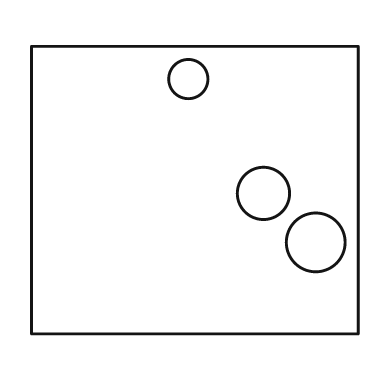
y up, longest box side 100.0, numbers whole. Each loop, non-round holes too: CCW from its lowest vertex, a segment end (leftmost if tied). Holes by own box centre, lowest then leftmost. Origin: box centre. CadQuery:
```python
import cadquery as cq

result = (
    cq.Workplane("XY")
    .moveTo(-50.0, -44.0)
    .lineTo(50.0, -44.0)
    .lineTo(50.0, 44.0)
    .lineTo(-50.0, 44.0)
    .close()
    .moveTo(37.0, -16.0)
    .circle(9.0)
    .moveTo(21.0, -1.0)
    .circle(8.0)
    .moveTo(-2.0, 34.0)
    .circle(6.0)
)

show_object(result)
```